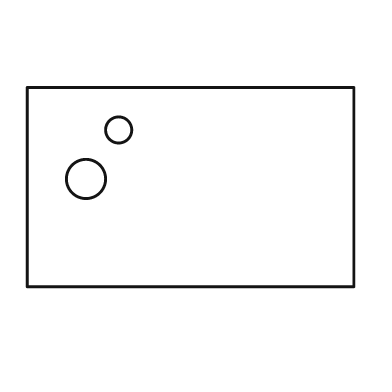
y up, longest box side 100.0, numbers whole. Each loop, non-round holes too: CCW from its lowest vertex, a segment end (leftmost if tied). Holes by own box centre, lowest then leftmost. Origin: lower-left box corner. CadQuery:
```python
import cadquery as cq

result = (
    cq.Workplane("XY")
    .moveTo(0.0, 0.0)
    .lineTo(100.0, 0.0)
    .lineTo(100.0, 61.0)
    .lineTo(0.0, 61.0)
    .close()
    .moveTo(18.0, 33.0)
    .circle(6.0)
    .moveTo(28.0, 48.0)
    .circle(4.0)
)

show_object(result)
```